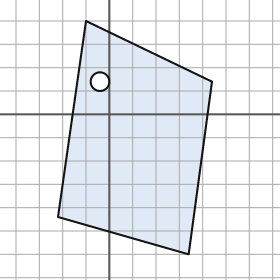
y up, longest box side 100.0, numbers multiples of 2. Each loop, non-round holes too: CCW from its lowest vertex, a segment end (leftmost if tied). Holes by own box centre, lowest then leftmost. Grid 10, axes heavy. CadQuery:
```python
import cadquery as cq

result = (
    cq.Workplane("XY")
    .moveTo(34.0, -60.0)
    .lineTo(44.0, 14.0)
    .lineTo(-10.0, 40.0)
    .lineTo(-22.0, -44.0)
    .close()
    .moveTo(-4.0, 14.0)
    .circle(4.0)
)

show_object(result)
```